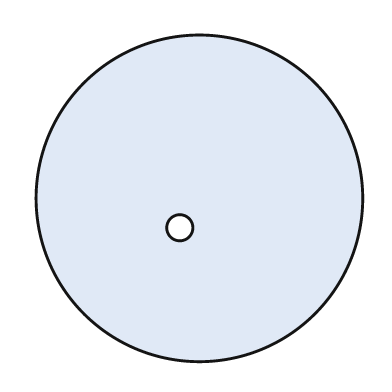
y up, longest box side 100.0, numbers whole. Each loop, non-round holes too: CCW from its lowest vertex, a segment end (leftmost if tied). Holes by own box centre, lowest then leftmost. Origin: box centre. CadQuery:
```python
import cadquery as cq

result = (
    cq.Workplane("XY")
    .moveTo(0.0, 0.0)
    .circle(50.0)
    .moveTo(-6.0, -9.0)
    .circle(4.0)
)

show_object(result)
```